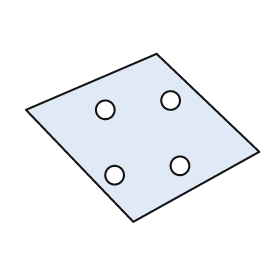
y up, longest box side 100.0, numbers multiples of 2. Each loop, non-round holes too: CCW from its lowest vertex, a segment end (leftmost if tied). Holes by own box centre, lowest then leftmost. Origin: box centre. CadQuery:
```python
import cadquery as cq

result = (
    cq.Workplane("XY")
    .moveTo(-4.0, -36.0)
    .lineTo(50.0, -6.0)
    .lineTo(6.0, 36.0)
    .lineTo(-50.0, 12.0)
    .close()
    .moveTo(-12.0, -16.0)
    .circle(4.0)
    .moveTo(16.0, -12.0)
    .circle(4.0)
    .moveTo(-16.0, 12.0)
    .circle(4.0)
    .moveTo(12.0, 16.0)
    .circle(4.0)
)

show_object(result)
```